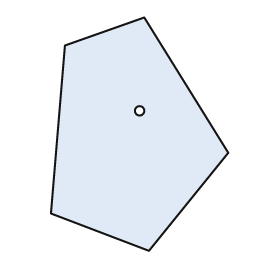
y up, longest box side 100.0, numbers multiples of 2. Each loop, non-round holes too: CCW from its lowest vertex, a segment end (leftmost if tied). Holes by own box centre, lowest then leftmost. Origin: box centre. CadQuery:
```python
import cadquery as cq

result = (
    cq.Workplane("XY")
    .moveTo(4.0, -50.0)
    .lineTo(38.0, -8.0)
    .lineTo(2.0, 50.0)
    .lineTo(-32.0, 38.0)
    .lineTo(-38.0, -34.0)
    .close()
    .moveTo(0.0, 10.0)
    .circle(2.0)
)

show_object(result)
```